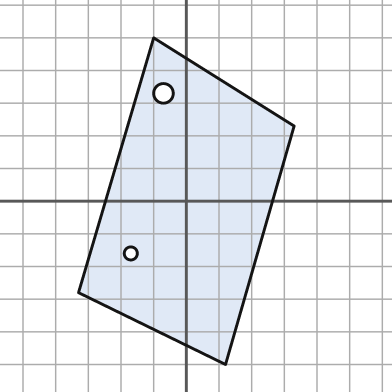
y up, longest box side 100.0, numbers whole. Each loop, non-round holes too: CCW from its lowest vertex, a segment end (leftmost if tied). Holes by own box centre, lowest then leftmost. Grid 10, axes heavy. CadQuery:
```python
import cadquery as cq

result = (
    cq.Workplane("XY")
    .moveTo(12.0, -50.0)
    .lineTo(33.0, 23.0)
    .lineTo(-10.0, 50.0)
    .lineTo(-33.0, -28.0)
    .close()
    .moveTo(-17.0, -16.0)
    .circle(2.0)
    .moveTo(-7.0, 33.0)
    .circle(3.0)
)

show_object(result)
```